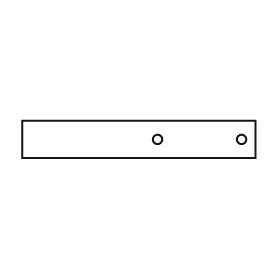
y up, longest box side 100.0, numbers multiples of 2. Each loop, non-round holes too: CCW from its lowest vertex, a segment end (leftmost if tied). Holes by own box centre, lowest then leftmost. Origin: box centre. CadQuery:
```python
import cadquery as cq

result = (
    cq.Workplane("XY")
    .moveTo(-50.0, -8.0)
    .lineTo(50.0, -8.0)
    .lineTo(50.0, 8.0)
    .lineTo(-50.0, 8.0)
    .close()
    .moveTo(8.0, 0.0)
    .circle(2.0)
    .moveTo(44.0, 0.0)
    .circle(2.0)
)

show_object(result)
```